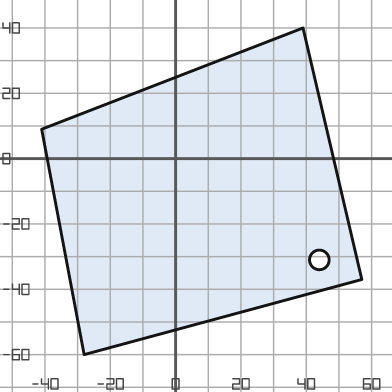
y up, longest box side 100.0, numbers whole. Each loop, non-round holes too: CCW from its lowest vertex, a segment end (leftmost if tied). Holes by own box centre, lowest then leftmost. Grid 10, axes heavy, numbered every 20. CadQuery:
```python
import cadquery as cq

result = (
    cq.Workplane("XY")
    .moveTo(-28.0, -60.0)
    .lineTo(57.0, -37.0)
    .lineTo(39.0, 40.0)
    .lineTo(-41.0, 9.0)
    .close()
    .moveTo(44.0, -31.0)
    .circle(3.0)
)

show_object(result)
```